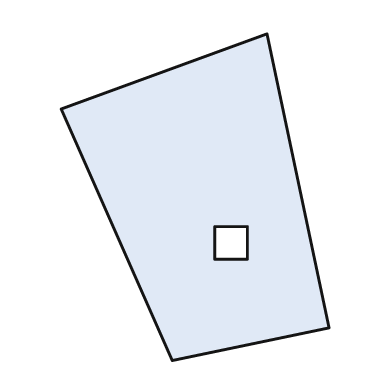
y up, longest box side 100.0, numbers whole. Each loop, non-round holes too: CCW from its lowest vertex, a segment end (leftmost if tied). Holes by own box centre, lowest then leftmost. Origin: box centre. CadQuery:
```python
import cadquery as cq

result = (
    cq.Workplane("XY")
    .moveTo(-7.0, -50.0)
    .lineTo(41.0, -40.0)
    .lineTo(22.0, 50.0)
    .lineTo(-41.0, 27.0)
    .close()
    .moveTo(6.0, -19.0)
    .lineTo(16.0, -19.0)
    .lineTo(16.0, -9.0)
    .lineTo(6.0, -9.0)
    .close()
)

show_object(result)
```